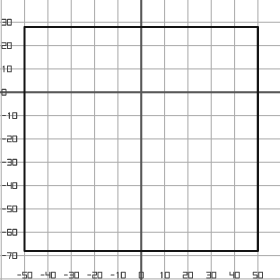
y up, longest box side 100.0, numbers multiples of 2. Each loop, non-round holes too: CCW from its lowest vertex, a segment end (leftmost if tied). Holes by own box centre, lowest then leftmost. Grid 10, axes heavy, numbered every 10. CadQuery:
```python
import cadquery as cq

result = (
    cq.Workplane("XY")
    .moveTo(-50.0, -68.0)
    .lineTo(50.0, -68.0)
    .lineTo(50.0, 28.0)
    .lineTo(-50.0, 28.0)
    .close()
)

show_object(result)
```